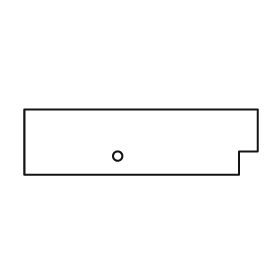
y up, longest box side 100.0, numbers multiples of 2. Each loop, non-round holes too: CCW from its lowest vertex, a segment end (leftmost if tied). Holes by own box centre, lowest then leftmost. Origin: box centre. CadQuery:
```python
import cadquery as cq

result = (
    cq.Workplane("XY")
    .moveTo(-50.0, -14.0)
    .lineTo(42.0, -14.0)
    .lineTo(42.0, -4.0)
    .lineTo(50.0, -4.0)
    .lineTo(50.0, 14.0)
    .lineTo(-50.0, 14.0)
    .close()
    .moveTo(-10.0, -6.0)
    .circle(2.0)
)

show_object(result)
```